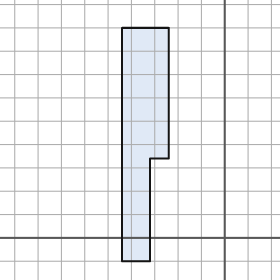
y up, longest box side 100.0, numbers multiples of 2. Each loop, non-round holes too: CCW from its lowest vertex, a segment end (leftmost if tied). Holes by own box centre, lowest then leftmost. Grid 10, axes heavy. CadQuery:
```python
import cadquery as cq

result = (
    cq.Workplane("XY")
    .moveTo(-44.0, -10.0)
    .lineTo(-32.0, -10.0)
    .lineTo(-32.0, 34.0)
    .lineTo(-24.0, 34.0)
    .lineTo(-24.0, 90.0)
    .lineTo(-44.0, 90.0)
    .close()
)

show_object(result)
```